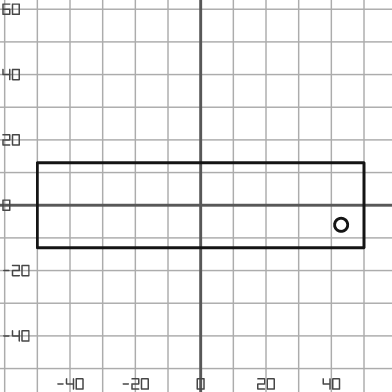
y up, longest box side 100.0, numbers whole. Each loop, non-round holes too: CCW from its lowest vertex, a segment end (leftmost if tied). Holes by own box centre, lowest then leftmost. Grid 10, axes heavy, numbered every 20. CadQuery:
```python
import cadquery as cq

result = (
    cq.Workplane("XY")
    .moveTo(-50.0, -13.0)
    .lineTo(50.0, -13.0)
    .lineTo(50.0, 13.0)
    .lineTo(-50.0, 13.0)
    .close()
    .moveTo(43.0, -6.0)
    .circle(2.0)
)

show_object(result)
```